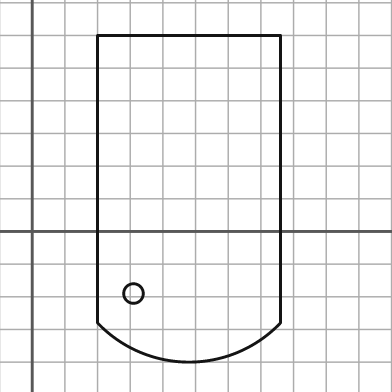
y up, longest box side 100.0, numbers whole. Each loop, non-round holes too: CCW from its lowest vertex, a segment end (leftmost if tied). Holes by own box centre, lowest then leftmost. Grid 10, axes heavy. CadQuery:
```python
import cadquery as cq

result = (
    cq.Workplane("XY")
    .moveTo(20.0, -28.0)
    .threePointArc((48.0, -40.0), (76.0, -28.0))
    .lineTo(76.0, 60.0)
    .lineTo(20.0, 60.0)
    .close()
    .moveTo(31.0, -19.0)
    .circle(3.0)
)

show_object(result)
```